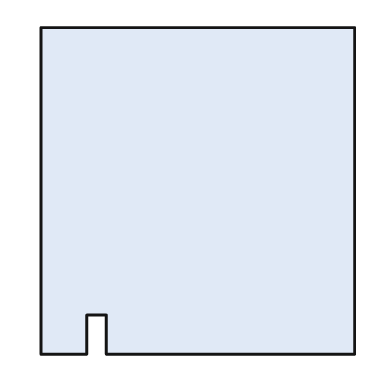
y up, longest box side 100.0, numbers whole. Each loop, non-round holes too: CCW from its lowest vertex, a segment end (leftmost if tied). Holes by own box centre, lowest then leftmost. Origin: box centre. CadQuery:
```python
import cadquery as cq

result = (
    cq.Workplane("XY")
    .moveTo(-48.0, -50.0)
    .lineTo(-34.0, -50.0)
    .lineTo(-34.0, -38.0)
    .lineTo(-28.0, -38.0)
    .lineTo(-28.0, -50.0)
    .lineTo(48.0, -50.0)
    .lineTo(48.0, 50.0)
    .lineTo(-48.0, 50.0)
    .close()
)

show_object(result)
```